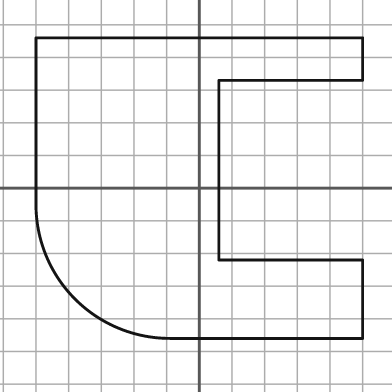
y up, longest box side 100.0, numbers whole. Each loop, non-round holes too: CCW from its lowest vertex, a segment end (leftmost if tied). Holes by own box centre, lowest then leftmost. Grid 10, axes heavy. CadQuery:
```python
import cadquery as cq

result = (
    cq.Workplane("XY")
    .moveTo(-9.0, -46.0)
    .lineTo(50.0, -46.0)
    .lineTo(50.0, -22.0)
    .lineTo(6.0, -22.0)
    .lineTo(6.0, 33.0)
    .lineTo(50.0, 33.0)
    .lineTo(50.0, 46.0)
    .lineTo(-50.0, 46.0)
    .lineTo(-50.0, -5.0)
    .threePointArc((-38.0, -34.0), (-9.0, -46.0))
    .close()
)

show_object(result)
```